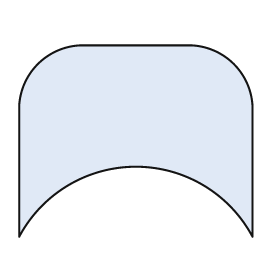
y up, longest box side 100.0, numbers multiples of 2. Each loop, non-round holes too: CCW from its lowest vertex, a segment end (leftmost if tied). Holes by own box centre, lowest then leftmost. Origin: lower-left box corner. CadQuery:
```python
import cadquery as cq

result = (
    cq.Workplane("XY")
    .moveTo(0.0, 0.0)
    .threePointArc((50.0, 30.0), (100.0, 0.0))
    .lineTo(100.0, 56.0)
    .threePointArc((92.0, 74.0), (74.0, 82.0))
    .lineTo(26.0, 82.0)
    .threePointArc((8.0, 74.0), (0.0, 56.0))
    .close()
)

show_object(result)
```